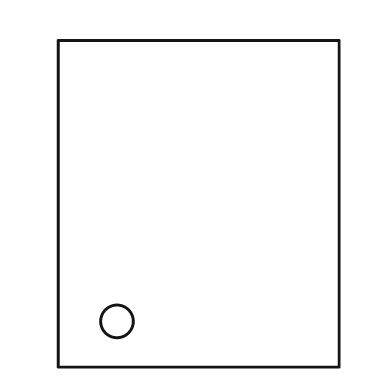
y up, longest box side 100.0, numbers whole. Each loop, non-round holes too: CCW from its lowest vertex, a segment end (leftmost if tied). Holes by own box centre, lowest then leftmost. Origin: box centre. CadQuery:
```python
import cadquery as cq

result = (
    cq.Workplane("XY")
    .moveTo(-43.0, -50.0)
    .lineTo(43.0, -50.0)
    .lineTo(43.0, 50.0)
    .lineTo(-43.0, 50.0)
    .close()
    .moveTo(-25.0, -36.0)
    .circle(5.0)
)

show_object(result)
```